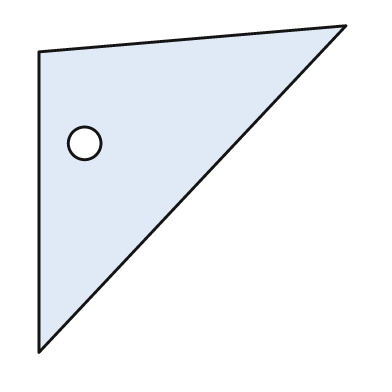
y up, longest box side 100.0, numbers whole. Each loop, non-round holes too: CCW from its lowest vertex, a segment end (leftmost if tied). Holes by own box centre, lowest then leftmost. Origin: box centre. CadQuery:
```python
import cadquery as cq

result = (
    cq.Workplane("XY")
    .moveTo(-47.0, -50.0)
    .lineTo(47.0, 50.0)
    .lineTo(-47.0, 42.0)
    .close()
    .moveTo(-33.0, 14.0)
    .circle(5.0)
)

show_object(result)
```